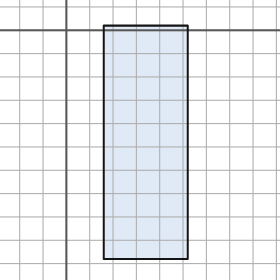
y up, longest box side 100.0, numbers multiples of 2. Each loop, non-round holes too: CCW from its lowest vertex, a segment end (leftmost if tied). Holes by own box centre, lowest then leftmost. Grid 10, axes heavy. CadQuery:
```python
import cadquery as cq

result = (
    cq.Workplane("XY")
    .moveTo(16.0, -98.0)
    .lineTo(52.0, -98.0)
    .lineTo(52.0, 2.0)
    .lineTo(16.0, 2.0)
    .close()
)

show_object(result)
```